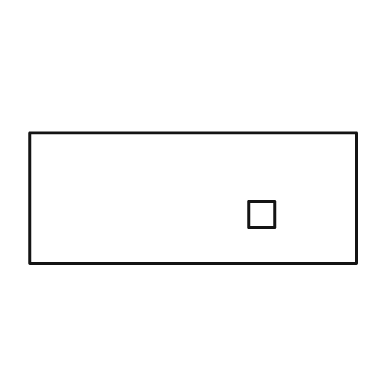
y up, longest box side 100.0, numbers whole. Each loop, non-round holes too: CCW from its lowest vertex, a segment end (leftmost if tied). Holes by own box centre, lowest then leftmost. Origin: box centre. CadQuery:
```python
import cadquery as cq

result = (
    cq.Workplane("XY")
    .moveTo(-50.0, -20.0)
    .lineTo(50.0, -20.0)
    .lineTo(50.0, 20.0)
    .lineTo(-50.0, 20.0)
    .close()
    .moveTo(17.0, -9.0)
    .lineTo(25.0, -9.0)
    .lineTo(25.0, -1.0)
    .lineTo(17.0, -1.0)
    .close()
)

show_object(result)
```